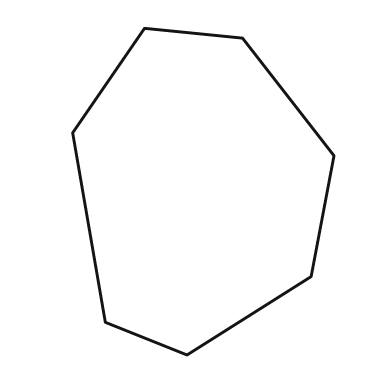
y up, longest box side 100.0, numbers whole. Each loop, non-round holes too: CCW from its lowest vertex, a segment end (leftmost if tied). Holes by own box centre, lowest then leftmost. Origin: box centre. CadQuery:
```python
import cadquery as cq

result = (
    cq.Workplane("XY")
    .moveTo(-5.0, -50.0)
    .lineTo(33.0, -26.0)
    .lineTo(40.0, 11.0)
    .lineTo(12.0, 47.0)
    .lineTo(-18.0, 50.0)
    .lineTo(-40.0, 18.0)
    .lineTo(-30.0, -40.0)
    .close()
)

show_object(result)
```